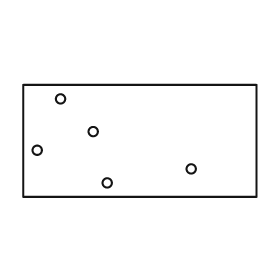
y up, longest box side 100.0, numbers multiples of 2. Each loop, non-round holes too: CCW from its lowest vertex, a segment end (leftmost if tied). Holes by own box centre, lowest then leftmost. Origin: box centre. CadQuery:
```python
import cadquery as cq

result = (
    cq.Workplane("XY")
    .moveTo(-50.0, -24.0)
    .lineTo(50.0, -24.0)
    .lineTo(50.0, 24.0)
    .lineTo(-50.0, 24.0)
    .close()
    .moveTo(-14.0, -18.0)
    .circle(2.0)
    .moveTo(22.0, -12.0)
    .circle(2.0)
    .moveTo(-44.0, -4.0)
    .circle(2.0)
    .moveTo(-20.0, 4.0)
    .circle(2.0)
    .moveTo(-34.0, 18.0)
    .circle(2.0)
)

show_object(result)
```